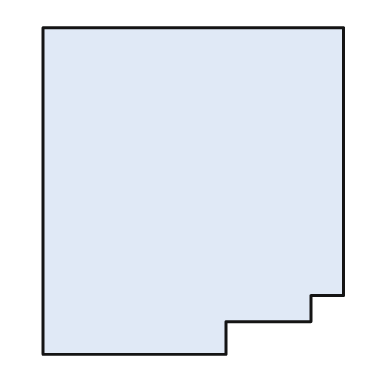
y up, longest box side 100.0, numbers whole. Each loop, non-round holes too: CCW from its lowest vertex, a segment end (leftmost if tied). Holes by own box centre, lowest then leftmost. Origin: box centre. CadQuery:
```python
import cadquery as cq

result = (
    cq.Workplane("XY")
    .moveTo(-46.0, -50.0)
    .lineTo(10.0, -50.0)
    .lineTo(10.0, -40.0)
    .lineTo(36.0, -40.0)
    .lineTo(36.0, -32.0)
    .lineTo(46.0, -32.0)
    .lineTo(46.0, 50.0)
    .lineTo(-46.0, 50.0)
    .close()
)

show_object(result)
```